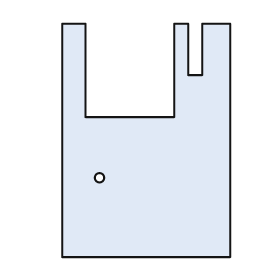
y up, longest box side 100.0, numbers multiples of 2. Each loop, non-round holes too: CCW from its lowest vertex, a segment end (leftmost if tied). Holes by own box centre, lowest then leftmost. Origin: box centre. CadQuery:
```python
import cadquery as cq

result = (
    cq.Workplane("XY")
    .moveTo(-36.0, -50.0)
    .lineTo(36.0, -50.0)
    .lineTo(36.0, 50.0)
    .lineTo(24.0, 50.0)
    .lineTo(24.0, 28.0)
    .lineTo(18.0, 28.0)
    .lineTo(18.0, 50.0)
    .lineTo(12.0, 50.0)
    .lineTo(12.0, 10.0)
    .lineTo(-26.0, 10.0)
    .lineTo(-26.0, 50.0)
    .lineTo(-36.0, 50.0)
    .close()
    .moveTo(-20.0, -16.0)
    .circle(2.0)
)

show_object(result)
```